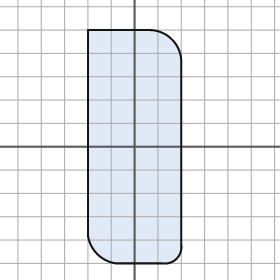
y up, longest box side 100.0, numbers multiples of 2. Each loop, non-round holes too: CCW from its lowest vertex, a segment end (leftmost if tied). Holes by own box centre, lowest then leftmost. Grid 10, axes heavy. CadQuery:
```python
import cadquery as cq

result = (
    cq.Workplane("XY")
    .moveTo(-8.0, -50.0)
    .lineTo(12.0, -50.0)
    .threePointArc((18.0, -48.0), (20.0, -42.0))
    .lineTo(20.0, 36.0)
    .threePointArc((16.0, 46.0), (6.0, 50.0))
    .lineTo(-20.0, 50.0)
    .lineTo(-20.0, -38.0)
    .threePointArc((-16.0, -46.0), (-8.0, -50.0))
    .close()
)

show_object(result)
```